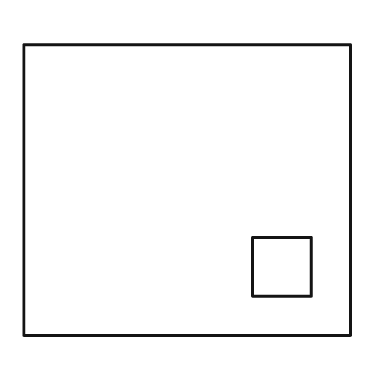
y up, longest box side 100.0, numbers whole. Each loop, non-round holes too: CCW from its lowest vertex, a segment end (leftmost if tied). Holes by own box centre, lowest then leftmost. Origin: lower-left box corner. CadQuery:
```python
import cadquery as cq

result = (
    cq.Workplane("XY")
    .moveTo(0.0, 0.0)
    .lineTo(100.0, 0.0)
    .lineTo(100.0, 89.0)
    .lineTo(0.0, 89.0)
    .close()
    .moveTo(70.0, 12.0)
    .lineTo(88.0, 12.0)
    .lineTo(88.0, 30.0)
    .lineTo(70.0, 30.0)
    .close()
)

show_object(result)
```